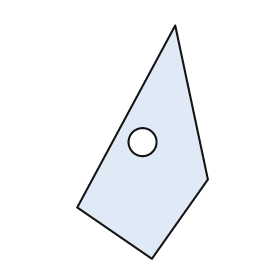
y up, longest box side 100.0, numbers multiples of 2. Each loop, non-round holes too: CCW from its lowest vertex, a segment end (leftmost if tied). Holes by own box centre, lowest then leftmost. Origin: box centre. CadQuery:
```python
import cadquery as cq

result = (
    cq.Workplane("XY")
    .moveTo(4.0, -50.0)
    .lineTo(28.0, -16.0)
    .lineTo(14.0, 50.0)
    .lineTo(-28.0, -28.0)
    .close()
    .moveTo(0.0, 0.0)
    .circle(6.0)
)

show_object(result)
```